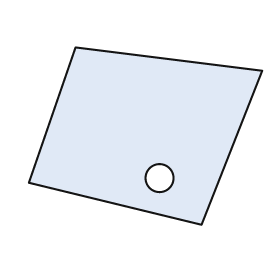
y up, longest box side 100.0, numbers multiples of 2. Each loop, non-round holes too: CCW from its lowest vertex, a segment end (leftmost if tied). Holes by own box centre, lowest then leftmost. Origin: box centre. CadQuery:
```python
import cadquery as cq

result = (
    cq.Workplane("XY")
    .moveTo(24.0, -38.0)
    .lineTo(50.0, 28.0)
    .lineTo(-30.0, 38.0)
    .lineTo(-50.0, -20.0)
    .close()
    .moveTo(6.0, -18.0)
    .circle(6.0)
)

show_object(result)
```